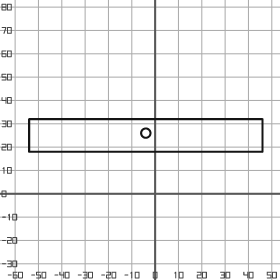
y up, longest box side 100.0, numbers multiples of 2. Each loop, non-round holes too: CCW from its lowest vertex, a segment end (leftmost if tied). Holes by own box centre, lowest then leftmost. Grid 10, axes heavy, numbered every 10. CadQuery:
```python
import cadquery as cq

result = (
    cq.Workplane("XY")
    .moveTo(-54.0, 18.0)
    .lineTo(46.0, 18.0)
    .lineTo(46.0, 32.0)
    .lineTo(-54.0, 32.0)
    .close()
    .moveTo(-4.0, 26.0)
    .circle(2.0)
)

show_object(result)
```